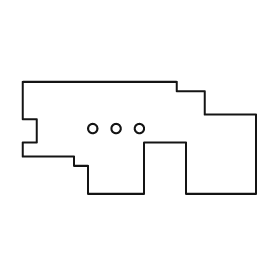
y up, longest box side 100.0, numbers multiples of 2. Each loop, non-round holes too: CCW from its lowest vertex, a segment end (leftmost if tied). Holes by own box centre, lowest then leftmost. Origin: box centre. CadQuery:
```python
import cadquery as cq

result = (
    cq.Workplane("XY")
    .moveTo(-22.0, -24.0)
    .lineTo(2.0, -24.0)
    .lineTo(2.0, -2.0)
    .lineTo(20.0, -2.0)
    .lineTo(20.0, -24.0)
    .lineTo(50.0, -24.0)
    .lineTo(50.0, 10.0)
    .lineTo(28.0, 10.0)
    .lineTo(28.0, 20.0)
    .lineTo(16.0, 20.0)
    .lineTo(16.0, 24.0)
    .lineTo(-50.0, 24.0)
    .lineTo(-50.0, 8.0)
    .lineTo(-44.0, 8.0)
    .lineTo(-44.0, -2.0)
    .lineTo(-50.0, -2.0)
    .lineTo(-50.0, -8.0)
    .lineTo(-28.0, -8.0)
    .lineTo(-28.0, -12.0)
    .lineTo(-22.0, -12.0)
    .close()
    .moveTo(-20.0, 4.0)
    .circle(2.0)
    .moveTo(-10.0, 4.0)
    .circle(2.0)
    .moveTo(0.0, 4.0)
    .circle(2.0)
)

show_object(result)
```